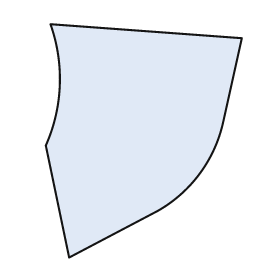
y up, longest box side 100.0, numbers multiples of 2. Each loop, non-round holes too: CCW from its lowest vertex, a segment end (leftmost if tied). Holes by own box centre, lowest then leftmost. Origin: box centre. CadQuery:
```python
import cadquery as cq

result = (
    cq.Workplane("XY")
    .moveTo(-32.0, -50.0)
    .lineTo(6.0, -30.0)
    .threePointArc((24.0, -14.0), (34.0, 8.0))
    .lineTo(42.0, 44.0)
    .lineTo(-40.0, 50.0)
    .threePointArc((-36.0, 24.0), (-42.0, -2.0))
    .close()
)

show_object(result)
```